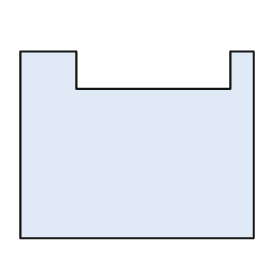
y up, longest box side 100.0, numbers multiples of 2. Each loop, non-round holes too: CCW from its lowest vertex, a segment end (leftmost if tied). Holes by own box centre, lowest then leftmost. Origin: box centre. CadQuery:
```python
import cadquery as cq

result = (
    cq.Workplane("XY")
    .moveTo(-50.0, -40.0)
    .lineTo(50.0, -40.0)
    .lineTo(50.0, 40.0)
    .lineTo(40.0, 40.0)
    .lineTo(40.0, 24.0)
    .lineTo(-26.0, 24.0)
    .lineTo(-26.0, 40.0)
    .lineTo(-50.0, 40.0)
    .close()
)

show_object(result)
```